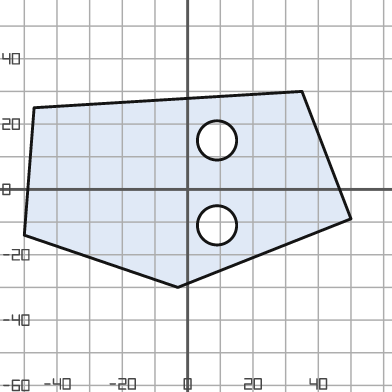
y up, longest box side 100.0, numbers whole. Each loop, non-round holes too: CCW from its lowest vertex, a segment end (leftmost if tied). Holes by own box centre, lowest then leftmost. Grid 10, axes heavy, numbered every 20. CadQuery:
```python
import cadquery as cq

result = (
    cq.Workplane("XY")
    .moveTo(-3.0, -30.0)
    .lineTo(50.0, -9.0)
    .lineTo(35.0, 30.0)
    .lineTo(-47.0, 25.0)
    .lineTo(-50.0, -14.0)
    .close()
    .moveTo(9.0, -11.0)
    .circle(6.0)
    .moveTo(9.0, 15.0)
    .circle(6.0)
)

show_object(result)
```